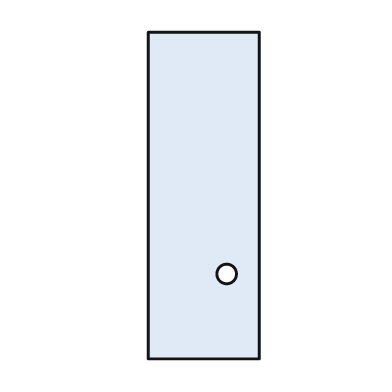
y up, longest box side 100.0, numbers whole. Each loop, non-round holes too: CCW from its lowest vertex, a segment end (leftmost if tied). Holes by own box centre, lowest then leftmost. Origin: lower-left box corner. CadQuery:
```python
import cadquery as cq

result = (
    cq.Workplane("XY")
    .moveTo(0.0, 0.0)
    .lineTo(34.0, 0.0)
    .lineTo(34.0, 100.0)
    .lineTo(0.0, 100.0)
    .close()
    .moveTo(24.0, 26.0)
    .circle(3.0)
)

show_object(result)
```